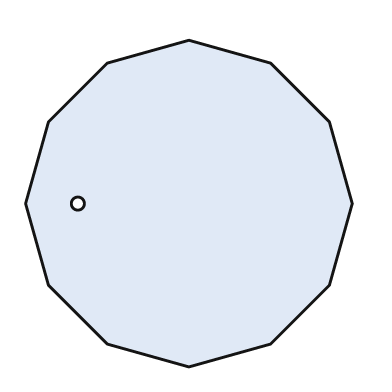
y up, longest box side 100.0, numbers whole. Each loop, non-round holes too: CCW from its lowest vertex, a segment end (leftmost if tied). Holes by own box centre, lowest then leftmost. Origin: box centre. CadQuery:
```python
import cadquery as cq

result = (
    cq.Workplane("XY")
    .moveTo(0.0, -50.0)
    .lineTo(25.0, -43.0)
    .lineTo(43.0, -25.0)
    .lineTo(50.0, 0.0)
    .lineTo(43.0, 25.0)
    .lineTo(25.0, 43.0)
    .lineTo(0.0, 50.0)
    .lineTo(-25.0, 43.0)
    .lineTo(-43.0, 25.0)
    .lineTo(-50.0, 0.0)
    .lineTo(-43.0, -25.0)
    .lineTo(-25.0, -43.0)
    .close()
    .moveTo(-34.0, 0.0)
    .circle(2.0)
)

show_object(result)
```